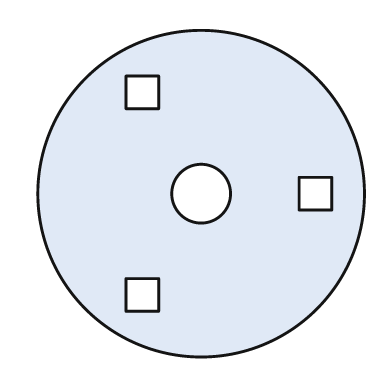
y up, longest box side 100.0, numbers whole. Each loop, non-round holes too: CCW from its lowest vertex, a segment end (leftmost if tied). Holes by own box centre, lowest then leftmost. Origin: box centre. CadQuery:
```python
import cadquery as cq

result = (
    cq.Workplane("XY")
    .moveTo(0.0, 0.0)
    .circle(50.0)
    .moveTo(-23.0, -36.0)
    .lineTo(-13.0, -36.0)
    .lineTo(-13.0, -26.0)
    .lineTo(-23.0, -26.0)
    .close()
    .moveTo(0.0, 0.0)
    .circle(9.0)
    .moveTo(30.0, -5.0)
    .lineTo(40.0, -5.0)
    .lineTo(40.0, 5.0)
    .lineTo(30.0, 5.0)
    .close()
    .moveTo(-23.0, 26.0)
    .lineTo(-13.0, 26.0)
    .lineTo(-13.0, 36.0)
    .lineTo(-23.0, 36.0)
    .close()
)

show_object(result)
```